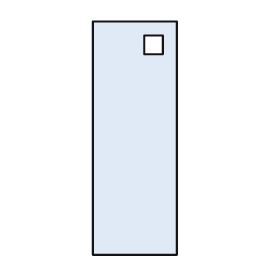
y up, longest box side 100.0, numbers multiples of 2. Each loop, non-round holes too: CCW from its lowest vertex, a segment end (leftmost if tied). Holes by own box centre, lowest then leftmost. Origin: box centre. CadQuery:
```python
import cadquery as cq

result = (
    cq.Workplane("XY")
    .moveTo(-18.0, -50.0)
    .lineTo(18.0, -50.0)
    .lineTo(18.0, 50.0)
    .lineTo(-18.0, 50.0)
    .close()
    .moveTo(4.0, 36.0)
    .lineTo(12.0, 36.0)
    .lineTo(12.0, 44.0)
    .lineTo(4.0, 44.0)
    .close()
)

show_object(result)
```